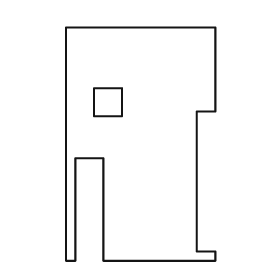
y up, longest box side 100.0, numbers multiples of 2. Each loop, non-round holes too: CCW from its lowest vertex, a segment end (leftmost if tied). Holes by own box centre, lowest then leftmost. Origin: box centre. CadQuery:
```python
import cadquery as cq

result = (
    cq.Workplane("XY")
    .moveTo(-32.0, -50.0)
    .lineTo(-28.0, -50.0)
    .lineTo(-28.0, -6.0)
    .lineTo(-16.0, -6.0)
    .lineTo(-16.0, -50.0)
    .lineTo(32.0, -50.0)
    .lineTo(32.0, -46.0)
    .lineTo(24.0, -46.0)
    .lineTo(24.0, 14.0)
    .lineTo(32.0, 14.0)
    .lineTo(32.0, 50.0)
    .lineTo(-32.0, 50.0)
    .close()
    .moveTo(-20.0, 12.0)
    .lineTo(-8.0, 12.0)
    .lineTo(-8.0, 24.0)
    .lineTo(-20.0, 24.0)
    .close()
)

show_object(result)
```